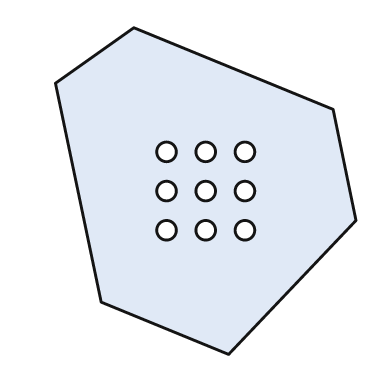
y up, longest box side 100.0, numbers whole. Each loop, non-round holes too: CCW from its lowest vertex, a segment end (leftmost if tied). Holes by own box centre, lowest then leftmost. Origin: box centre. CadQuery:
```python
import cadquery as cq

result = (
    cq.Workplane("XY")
    .moveTo(7.0, -50.0)
    .lineTo(46.0, -9.0)
    .lineTo(39.0, 25.0)
    .lineTo(-22.0, 50.0)
    .lineTo(-46.0, 33.0)
    .lineTo(-32.0, -34.0)
    .close()
    .moveTo(-12.0, -12.0)
    .circle(3.0)
    .moveTo(0.0, -12.0)
    .circle(3.0)
    .moveTo(12.0, -12.0)
    .circle(3.0)
    .moveTo(-12.0, 0.0)
    .circle(3.0)
    .moveTo(0.0, 0.0)
    .circle(3.0)
    .moveTo(12.0, 0.0)
    .circle(3.0)
    .moveTo(-12.0, 12.0)
    .circle(3.0)
    .moveTo(0.0, 12.0)
    .circle(3.0)
    .moveTo(12.0, 12.0)
    .circle(3.0)
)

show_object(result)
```